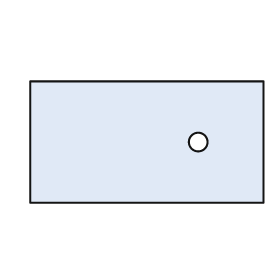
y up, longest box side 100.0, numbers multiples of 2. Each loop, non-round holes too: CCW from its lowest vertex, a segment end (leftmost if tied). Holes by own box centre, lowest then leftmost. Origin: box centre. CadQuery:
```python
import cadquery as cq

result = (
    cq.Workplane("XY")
    .moveTo(-50.0, -26.0)
    .lineTo(50.0, -26.0)
    .lineTo(50.0, 26.0)
    .lineTo(-50.0, 26.0)
    .close()
    .moveTo(22.0, 0.0)
    .circle(4.0)
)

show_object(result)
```